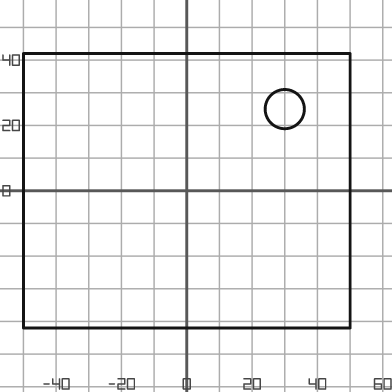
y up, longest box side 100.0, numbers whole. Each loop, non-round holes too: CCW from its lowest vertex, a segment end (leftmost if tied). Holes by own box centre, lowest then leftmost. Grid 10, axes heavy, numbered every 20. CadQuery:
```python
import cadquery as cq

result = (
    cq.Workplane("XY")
    .moveTo(-50.0, -42.0)
    .lineTo(50.0, -42.0)
    .lineTo(50.0, 42.0)
    .lineTo(-50.0, 42.0)
    .close()
    .moveTo(30.0, 25.0)
    .circle(6.0)
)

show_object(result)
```